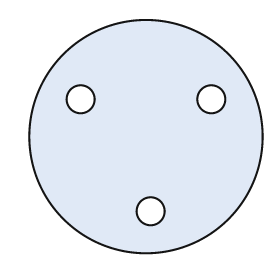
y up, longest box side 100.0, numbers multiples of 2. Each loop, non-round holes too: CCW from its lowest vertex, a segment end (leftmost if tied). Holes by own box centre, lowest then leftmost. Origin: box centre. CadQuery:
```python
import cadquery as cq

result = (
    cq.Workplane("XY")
    .moveTo(0.0, 0.0)
    .circle(50.0)
    .moveTo(2.0, -32.0)
    .circle(6.0)
    .moveTo(-28.0, 16.0)
    .circle(6.0)
    .moveTo(28.0, 16.0)
    .circle(6.0)
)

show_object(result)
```